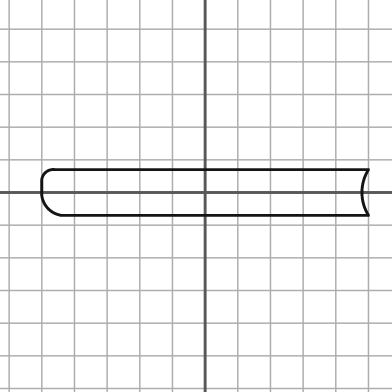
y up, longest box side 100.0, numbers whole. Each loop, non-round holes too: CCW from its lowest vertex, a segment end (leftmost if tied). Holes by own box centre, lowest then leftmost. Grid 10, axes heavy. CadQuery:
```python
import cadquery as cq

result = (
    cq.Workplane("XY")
    .moveTo(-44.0, -7.0)
    .lineTo(50.0, -7.0)
    .threePointArc((48.0, 0.0), (50.0, 7.0))
    .lineTo(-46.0, 7.0)
    .threePointArc((-49.0, 6.0), (-50.0, 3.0))
    .lineTo(-50.0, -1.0)
    .threePointArc((-48.0, -5.0), (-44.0, -7.0))
    .close()
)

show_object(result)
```